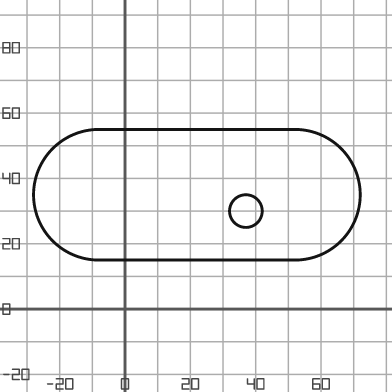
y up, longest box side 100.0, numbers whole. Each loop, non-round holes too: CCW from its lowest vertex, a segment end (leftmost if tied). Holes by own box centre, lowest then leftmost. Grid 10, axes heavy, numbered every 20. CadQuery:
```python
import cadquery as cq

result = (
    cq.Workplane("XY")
    .moveTo(-8.0, 15.0)
    .lineTo(52.0, 15.0)
    .threePointArc((72.0, 35.0), (52.0, 55.0))
    .lineTo(-8.0, 55.0)
    .threePointArc((-28.0, 35.0), (-8.0, 15.0))
    .close()
    .moveTo(37.0, 30.0)
    .circle(5.0)
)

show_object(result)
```